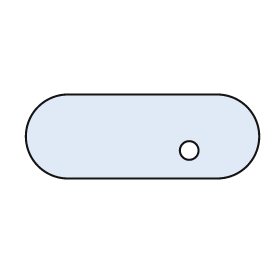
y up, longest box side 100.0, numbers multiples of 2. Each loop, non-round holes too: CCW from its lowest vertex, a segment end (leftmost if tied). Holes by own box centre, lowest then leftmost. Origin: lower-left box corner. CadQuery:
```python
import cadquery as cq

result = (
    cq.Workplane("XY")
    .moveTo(18.0, 0.0)
    .lineTo(82.0, 0.0)
    .threePointArc((100.0, 18.0), (82.0, 36.0))
    .lineTo(18.0, 36.0)
    .threePointArc((0.0, 18.0), (18.0, 0.0))
    .close()
    .moveTo(70.0, 12.0)
    .circle(4.0)
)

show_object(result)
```